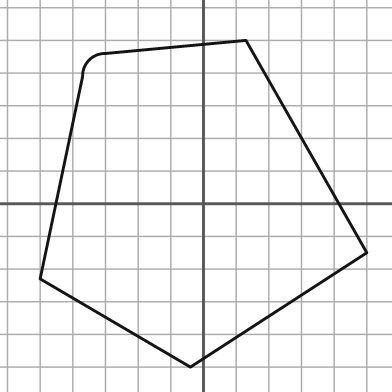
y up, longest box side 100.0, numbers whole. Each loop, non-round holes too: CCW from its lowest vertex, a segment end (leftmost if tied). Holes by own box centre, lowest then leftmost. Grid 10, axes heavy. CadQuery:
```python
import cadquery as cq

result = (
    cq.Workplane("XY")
    .moveTo(-4.0, -50.0)
    .lineTo(50.0, -15.0)
    .lineTo(13.0, 50.0)
    .lineTo(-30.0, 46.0)
    .threePointArc((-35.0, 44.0), (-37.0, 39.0))
    .lineTo(-50.0, -23.0)
    .close()
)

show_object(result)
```